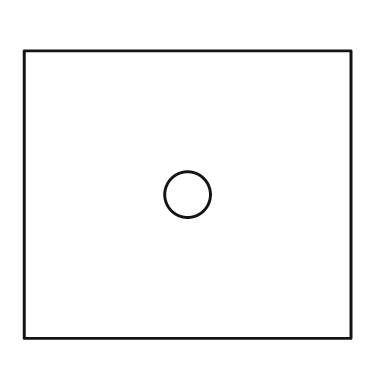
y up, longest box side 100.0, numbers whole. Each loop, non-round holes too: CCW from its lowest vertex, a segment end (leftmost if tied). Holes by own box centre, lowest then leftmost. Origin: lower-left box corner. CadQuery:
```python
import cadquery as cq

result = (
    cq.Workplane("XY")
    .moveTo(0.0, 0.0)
    .lineTo(100.0, 0.0)
    .lineTo(100.0, 88.0)
    .lineTo(0.0, 88.0)
    .close()
    .moveTo(50.0, 44.0)
    .circle(7.0)
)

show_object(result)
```